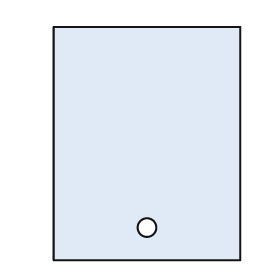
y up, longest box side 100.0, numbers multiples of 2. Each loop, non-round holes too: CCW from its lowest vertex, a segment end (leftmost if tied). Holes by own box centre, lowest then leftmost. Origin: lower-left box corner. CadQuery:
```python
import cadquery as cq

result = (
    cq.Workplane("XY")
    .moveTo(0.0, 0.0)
    .lineTo(80.0, 0.0)
    .lineTo(80.0, 100.0)
    .lineTo(0.0, 100.0)
    .close()
    .moveTo(40.0, 14.0)
    .circle(4.0)
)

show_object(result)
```